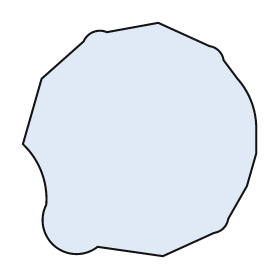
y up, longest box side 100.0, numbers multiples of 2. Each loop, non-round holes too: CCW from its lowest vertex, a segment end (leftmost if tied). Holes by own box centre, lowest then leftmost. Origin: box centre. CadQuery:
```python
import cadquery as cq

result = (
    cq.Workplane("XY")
    .moveTo(10.0, -50.0)
    .lineTo(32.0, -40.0)
    .threePointArc((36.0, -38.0), (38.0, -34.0))
    .lineTo(46.0, -20.0)
    .lineTo(50.0, -6.0)
    .lineTo(50.0, 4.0)
    .threePointArc((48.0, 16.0), (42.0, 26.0))
    .lineTo(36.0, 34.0)
    .threePointArc((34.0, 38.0), (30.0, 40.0))
    .lineTo(8.0, 50.0)
    .lineTo(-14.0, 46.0)
    .threePointArc((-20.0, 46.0), (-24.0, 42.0))
    .lineTo(-42.0, 26.0)
    .lineTo(-50.0, -2.0)
    .threePointArc((-42.0, -14.0), (-40.0, -28.0))
    .threePointArc((-36.0, -46.0), (-18.0, -46.0))
    .close()
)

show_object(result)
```